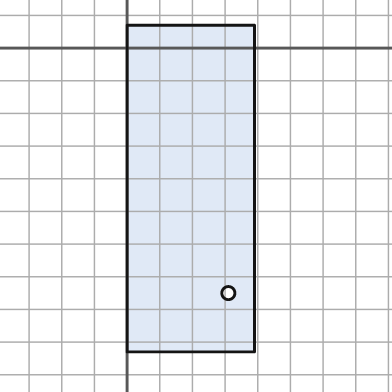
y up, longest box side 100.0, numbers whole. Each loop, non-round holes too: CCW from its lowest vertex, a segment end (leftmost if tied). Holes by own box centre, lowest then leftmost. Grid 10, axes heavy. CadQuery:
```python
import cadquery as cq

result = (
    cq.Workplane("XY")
    .moveTo(0.0, -93.0)
    .lineTo(39.0, -93.0)
    .lineTo(39.0, 7.0)
    .lineTo(0.0, 7.0)
    .close()
    .moveTo(31.0, -75.0)
    .circle(2.0)
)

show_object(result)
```